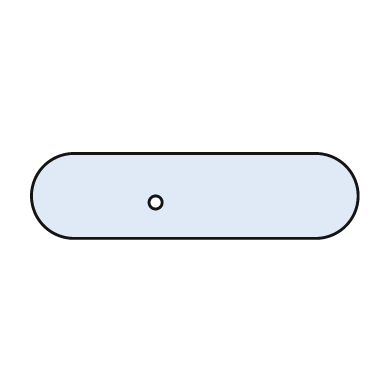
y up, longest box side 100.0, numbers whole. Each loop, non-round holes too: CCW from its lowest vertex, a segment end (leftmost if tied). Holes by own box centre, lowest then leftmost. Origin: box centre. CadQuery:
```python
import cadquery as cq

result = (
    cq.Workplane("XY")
    .moveTo(-37.0, -13.0)
    .lineTo(37.0, -13.0)
    .threePointArc((50.0, 0.0), (37.0, 13.0))
    .lineTo(-37.0, 13.0)
    .threePointArc((-50.0, 0.0), (-37.0, -13.0))
    .close()
    .moveTo(-12.0, -2.0)
    .circle(2.0)
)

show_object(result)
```